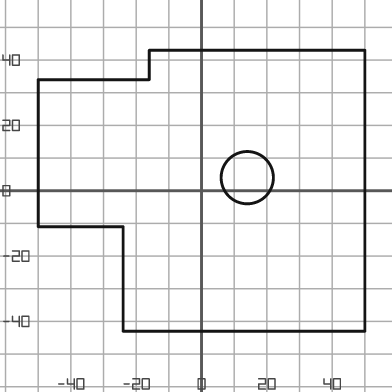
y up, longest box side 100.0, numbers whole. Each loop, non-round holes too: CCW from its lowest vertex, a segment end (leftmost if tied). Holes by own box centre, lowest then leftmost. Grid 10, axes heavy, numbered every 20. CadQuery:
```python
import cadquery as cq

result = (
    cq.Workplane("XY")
    .moveTo(-24.0, -43.0)
    .lineTo(50.0, -43.0)
    .lineTo(50.0, 43.0)
    .lineTo(-16.0, 43.0)
    .lineTo(-16.0, 34.0)
    .lineTo(-50.0, 34.0)
    .lineTo(-50.0, -11.0)
    .lineTo(-24.0, -11.0)
    .close()
    .moveTo(14.0, 4.0)
    .circle(8.0)
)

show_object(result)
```